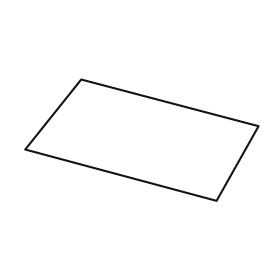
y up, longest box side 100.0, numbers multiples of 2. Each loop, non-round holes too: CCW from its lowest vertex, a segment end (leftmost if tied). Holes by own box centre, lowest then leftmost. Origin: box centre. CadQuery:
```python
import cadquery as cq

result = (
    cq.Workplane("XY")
    .moveTo(32.0, -26.0)
    .lineTo(50.0, 6.0)
    .lineTo(-26.0, 26.0)
    .lineTo(-50.0, -4.0)
    .close()
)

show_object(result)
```